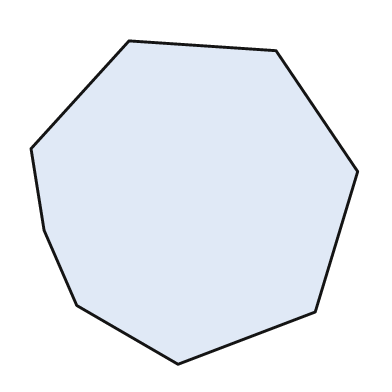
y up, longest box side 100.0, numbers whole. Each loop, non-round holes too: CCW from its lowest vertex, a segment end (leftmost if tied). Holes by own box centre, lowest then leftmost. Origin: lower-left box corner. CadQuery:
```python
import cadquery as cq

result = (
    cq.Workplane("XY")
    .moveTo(45.0, 0.0)
    .lineTo(87.0, 16.0)
    .lineTo(100.0, 59.0)
    .lineTo(75.0, 96.0)
    .lineTo(30.0, 99.0)
    .lineTo(0.0, 66.0)
    .lineTo(4.0, 41.0)
    .lineTo(14.0, 18.0)
    .close()
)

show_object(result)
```